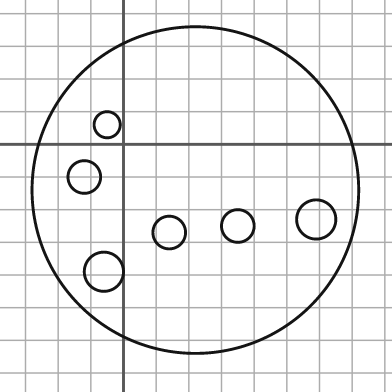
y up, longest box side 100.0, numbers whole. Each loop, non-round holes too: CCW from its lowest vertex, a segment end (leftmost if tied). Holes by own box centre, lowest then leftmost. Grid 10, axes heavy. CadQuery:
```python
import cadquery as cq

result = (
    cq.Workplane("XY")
    .moveTo(22.0, -14.0)
    .circle(50.0)
    .moveTo(-6.0, -39.0)
    .circle(6.0)
    .moveTo(14.0, -27.0)
    .circle(5.0)
    .moveTo(35.0, -25.0)
    .circle(5.0)
    .moveTo(59.0, -23.0)
    .circle(6.0)
    .moveTo(-12.0, -10.0)
    .circle(5.0)
    .moveTo(-5.0, 6.0)
    .circle(4.0)
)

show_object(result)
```